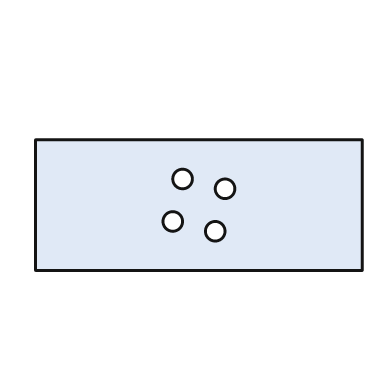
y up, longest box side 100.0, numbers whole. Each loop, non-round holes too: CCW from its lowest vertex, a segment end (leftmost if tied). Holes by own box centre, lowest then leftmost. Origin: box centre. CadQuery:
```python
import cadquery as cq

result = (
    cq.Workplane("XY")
    .moveTo(-50.0, -20.0)
    .lineTo(50.0, -20.0)
    .lineTo(50.0, 20.0)
    .lineTo(-50.0, 20.0)
    .close()
    .moveTo(5.0, -8.0)
    .circle(3.0)
    .moveTo(-8.0, -5.0)
    .circle(3.0)
    .moveTo(8.0, 5.0)
    .circle(3.0)
    .moveTo(-5.0, 8.0)
    .circle(3.0)
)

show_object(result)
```